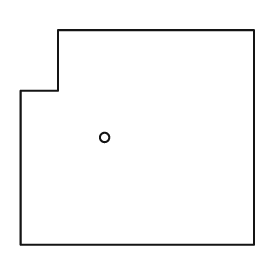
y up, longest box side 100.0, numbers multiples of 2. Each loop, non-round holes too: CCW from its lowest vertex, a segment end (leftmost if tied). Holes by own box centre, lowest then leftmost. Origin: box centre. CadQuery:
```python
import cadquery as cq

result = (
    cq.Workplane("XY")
    .moveTo(-50.0, -46.0)
    .lineTo(50.0, -46.0)
    .lineTo(50.0, 46.0)
    .lineTo(-34.0, 46.0)
    .lineTo(-34.0, 20.0)
    .lineTo(-50.0, 20.0)
    .close()
    .moveTo(-14.0, 0.0)
    .circle(2.0)
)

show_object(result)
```